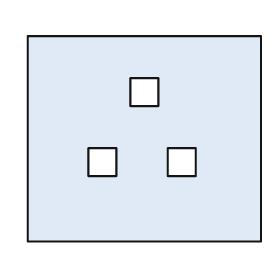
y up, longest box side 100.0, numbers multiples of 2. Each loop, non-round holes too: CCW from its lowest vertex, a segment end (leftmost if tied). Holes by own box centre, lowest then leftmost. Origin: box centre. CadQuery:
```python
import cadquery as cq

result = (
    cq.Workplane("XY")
    .moveTo(-50.0, -44.0)
    .lineTo(50.0, -44.0)
    .lineTo(50.0, 44.0)
    .lineTo(-50.0, 44.0)
    .close()
    .moveTo(-24.0, -16.0)
    .lineTo(-12.0, -16.0)
    .lineTo(-12.0, -4.0)
    .lineTo(-24.0, -4.0)
    .close()
    .moveTo(10.0, -16.0)
    .lineTo(22.0, -16.0)
    .lineTo(22.0, -4.0)
    .lineTo(10.0, -4.0)
    .close()
    .moveTo(-6.0, 14.0)
    .lineTo(6.0, 14.0)
    .lineTo(6.0, 26.0)
    .lineTo(-6.0, 26.0)
    .close()
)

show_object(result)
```